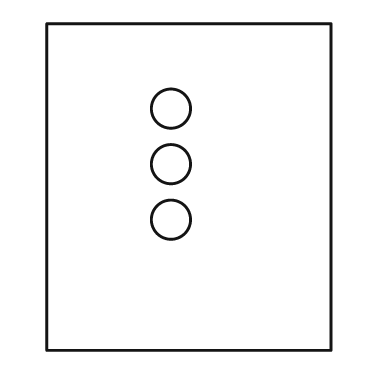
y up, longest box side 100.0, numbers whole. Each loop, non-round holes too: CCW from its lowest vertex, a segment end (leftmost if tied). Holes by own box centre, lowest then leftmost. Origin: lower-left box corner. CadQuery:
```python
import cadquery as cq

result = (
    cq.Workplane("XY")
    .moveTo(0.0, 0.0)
    .lineTo(87.0, 0.0)
    .lineTo(87.0, 100.0)
    .lineTo(0.0, 100.0)
    .close()
    .moveTo(38.0, 40.0)
    .circle(6.0)
    .moveTo(38.0, 57.0)
    .circle(6.0)
    .moveTo(38.0, 74.0)
    .circle(6.0)
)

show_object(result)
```